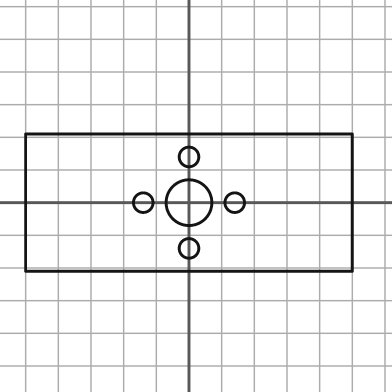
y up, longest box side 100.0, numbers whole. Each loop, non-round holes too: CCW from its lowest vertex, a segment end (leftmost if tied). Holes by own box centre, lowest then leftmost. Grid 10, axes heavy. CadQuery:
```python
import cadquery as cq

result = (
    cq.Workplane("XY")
    .moveTo(-50.0, -21.0)
    .lineTo(50.0, -21.0)
    .lineTo(50.0, 21.0)
    .lineTo(-50.0, 21.0)
    .close()
    .moveTo(0.0, -14.0)
    .circle(3.0)
    .moveTo(-14.0, 0.0)
    .circle(3.0)
    .moveTo(0.0, 0.0)
    .circle(7.0)
    .moveTo(14.0, 0.0)
    .circle(3.0)
    .moveTo(0.0, 14.0)
    .circle(3.0)
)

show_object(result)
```